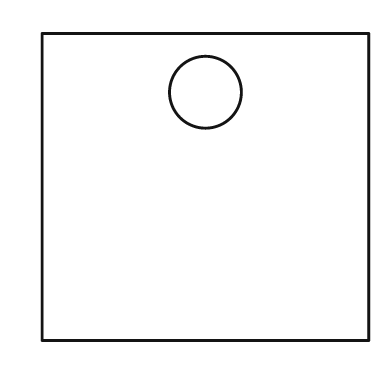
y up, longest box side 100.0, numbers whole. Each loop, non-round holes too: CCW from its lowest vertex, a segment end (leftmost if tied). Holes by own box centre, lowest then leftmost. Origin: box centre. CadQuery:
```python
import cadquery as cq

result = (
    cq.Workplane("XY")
    .moveTo(-50.0, -47.0)
    .lineTo(50.0, -47.0)
    .lineTo(50.0, 47.0)
    .lineTo(-50.0, 47.0)
    .close()
    .moveTo(0.0, 29.0)
    .circle(11.0)
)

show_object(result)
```